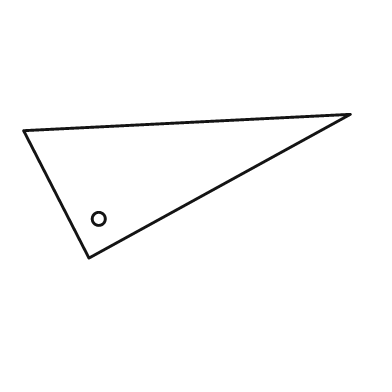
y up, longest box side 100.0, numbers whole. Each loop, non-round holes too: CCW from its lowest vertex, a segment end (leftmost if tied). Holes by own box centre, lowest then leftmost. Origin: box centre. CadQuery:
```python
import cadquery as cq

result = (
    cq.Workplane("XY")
    .moveTo(-30.0, -22.0)
    .lineTo(50.0, 22.0)
    .lineTo(-50.0, 17.0)
    .close()
    .moveTo(-27.0, -10.0)
    .circle(2.0)
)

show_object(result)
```